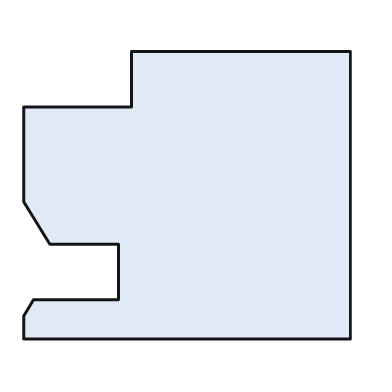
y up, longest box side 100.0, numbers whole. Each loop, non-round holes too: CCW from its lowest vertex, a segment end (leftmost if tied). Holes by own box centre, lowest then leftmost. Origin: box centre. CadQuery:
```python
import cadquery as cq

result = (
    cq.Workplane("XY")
    .moveTo(-50.0, -44.0)
    .lineTo(50.0, -44.0)
    .lineTo(50.0, 44.0)
    .lineTo(-17.0, 44.0)
    .lineTo(-17.0, 27.0)
    .lineTo(-50.0, 27.0)
    .lineTo(-50.0, -2.0)
    .lineTo(-42.0, -15.0)
    .lineTo(-21.0, -15.0)
    .lineTo(-21.0, -32.0)
    .lineTo(-47.0, -32.0)
    .lineTo(-50.0, -37.0)
    .close()
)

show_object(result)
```